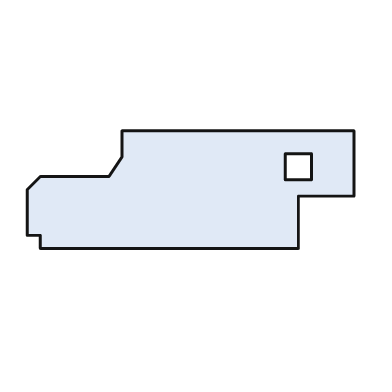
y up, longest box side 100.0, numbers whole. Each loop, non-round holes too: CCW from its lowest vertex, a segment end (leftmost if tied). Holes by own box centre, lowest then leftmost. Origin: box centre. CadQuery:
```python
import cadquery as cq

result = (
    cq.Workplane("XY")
    .moveTo(-46.0, -18.0)
    .lineTo(33.0, -18.0)
    .lineTo(33.0, -2.0)
    .lineTo(50.0, -2.0)
    .lineTo(50.0, 18.0)
    .lineTo(-21.0, 18.0)
    .lineTo(-21.0, 10.0)
    .lineTo(-25.0, 4.0)
    .lineTo(-46.0, 4.0)
    .lineTo(-50.0, 0.0)
    .lineTo(-50.0, -14.0)
    .lineTo(-46.0, -14.0)
    .close()
    .moveTo(29.0, 3.0)
    .lineTo(37.0, 3.0)
    .lineTo(37.0, 11.0)
    .lineTo(29.0, 11.0)
    .close()
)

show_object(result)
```